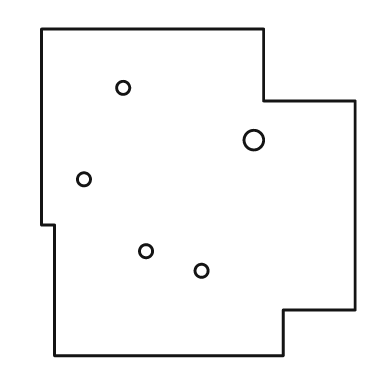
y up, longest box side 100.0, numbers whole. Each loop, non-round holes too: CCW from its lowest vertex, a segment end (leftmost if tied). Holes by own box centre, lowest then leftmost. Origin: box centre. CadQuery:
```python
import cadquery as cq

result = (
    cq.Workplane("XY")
    .moveTo(-44.0, -50.0)
    .lineTo(26.0, -50.0)
    .lineTo(26.0, -36.0)
    .lineTo(48.0, -36.0)
    .lineTo(48.0, 28.0)
    .lineTo(20.0, 28.0)
    .lineTo(20.0, 50.0)
    .lineTo(-48.0, 50.0)
    .lineTo(-48.0, -10.0)
    .lineTo(-44.0, -10.0)
    .close()
    .moveTo(1.0, -24.0)
    .circle(2.0)
    .moveTo(-16.0, -18.0)
    .circle(2.0)
    .moveTo(-35.0, 4.0)
    .circle(2.0)
    .moveTo(17.0, 16.0)
    .circle(3.0)
    .moveTo(-23.0, 32.0)
    .circle(2.0)
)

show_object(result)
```